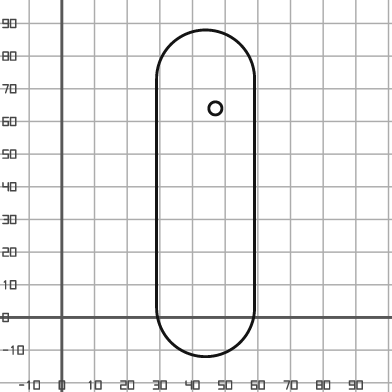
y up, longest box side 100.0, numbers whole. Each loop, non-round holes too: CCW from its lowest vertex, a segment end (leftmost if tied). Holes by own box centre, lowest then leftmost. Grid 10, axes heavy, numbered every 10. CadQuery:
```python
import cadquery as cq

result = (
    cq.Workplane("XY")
    .moveTo(29.0, 3.0)
    .threePointArc((44.0, -12.0), (59.0, 3.0))
    .lineTo(59.0, 73.0)
    .threePointArc((44.0, 88.0), (29.0, 73.0))
    .close()
    .moveTo(47.0, 64.0)
    .circle(2.0)
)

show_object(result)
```